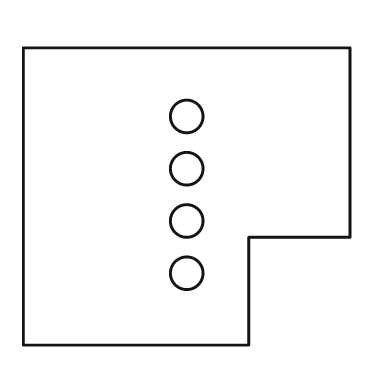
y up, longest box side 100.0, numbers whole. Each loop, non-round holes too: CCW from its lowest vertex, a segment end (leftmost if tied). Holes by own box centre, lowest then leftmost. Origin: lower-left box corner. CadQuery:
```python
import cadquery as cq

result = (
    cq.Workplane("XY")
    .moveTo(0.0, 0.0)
    .lineTo(69.0, 0.0)
    .lineTo(69.0, 33.0)
    .lineTo(100.0, 33.0)
    .lineTo(100.0, 91.0)
    .lineTo(0.0, 91.0)
    .close()
    .moveTo(50.0, 22.0)
    .circle(5.0)
    .moveTo(50.0, 38.0)
    .circle(5.0)
    .moveTo(50.0, 54.0)
    .circle(5.0)
    .moveTo(50.0, 70.0)
    .circle(5.0)
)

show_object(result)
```